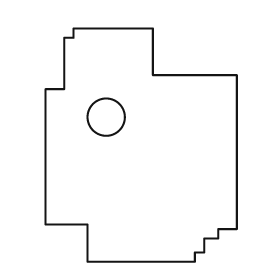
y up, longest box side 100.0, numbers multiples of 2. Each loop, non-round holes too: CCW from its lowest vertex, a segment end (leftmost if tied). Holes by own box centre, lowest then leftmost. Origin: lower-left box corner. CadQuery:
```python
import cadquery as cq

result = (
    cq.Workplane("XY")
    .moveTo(18.0, 0.0)
    .lineTo(64.0, 0.0)
    .lineTo(64.0, 4.0)
    .lineTo(68.0, 4.0)
    .lineTo(68.0, 10.0)
    .lineTo(74.0, 10.0)
    .lineTo(74.0, 14.0)
    .lineTo(82.0, 14.0)
    .lineTo(82.0, 80.0)
    .lineTo(46.0, 80.0)
    .lineTo(46.0, 100.0)
    .lineTo(12.0, 100.0)
    .lineTo(12.0, 96.0)
    .lineTo(8.0, 96.0)
    .lineTo(8.0, 74.0)
    .lineTo(0.0, 74.0)
    .lineTo(0.0, 16.0)
    .lineTo(18.0, 16.0)
    .close()
    .moveTo(26.0, 62.0)
    .circle(8.0)
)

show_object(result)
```